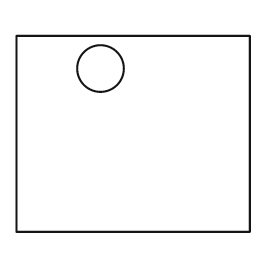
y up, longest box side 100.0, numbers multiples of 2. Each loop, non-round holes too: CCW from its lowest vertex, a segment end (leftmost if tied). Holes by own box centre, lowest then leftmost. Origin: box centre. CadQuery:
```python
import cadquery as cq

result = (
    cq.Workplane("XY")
    .moveTo(-50.0, -42.0)
    .lineTo(50.0, -42.0)
    .lineTo(50.0, 42.0)
    .lineTo(-50.0, 42.0)
    .close()
    .moveTo(-14.0, 28.0)
    .circle(10.0)
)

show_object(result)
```